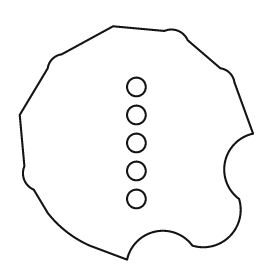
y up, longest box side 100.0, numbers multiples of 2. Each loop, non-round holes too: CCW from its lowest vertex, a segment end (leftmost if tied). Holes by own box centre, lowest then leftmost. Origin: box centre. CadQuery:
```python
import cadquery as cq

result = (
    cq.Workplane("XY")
    .moveTo(-4.0, -50.0)
    .threePointArc((8.0, -38.0), (24.0, -44.0))
    .threePointArc((40.0, -40.0), (44.0, -24.0))
    .threePointArc((38.0, -8.0), (50.0, 4.0))
    .lineTo(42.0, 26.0)
    .threePointArc((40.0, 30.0), (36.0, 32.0))
    .lineTo(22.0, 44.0)
    .threePointArc((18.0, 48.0), (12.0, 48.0))
    .lineTo(-10.0, 50.0)
    .lineTo(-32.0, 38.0)
    .threePointArc((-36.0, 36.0), (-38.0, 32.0))
    .lineTo(-50.0, 12.0)
    .lineTo(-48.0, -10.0)
    .threePointArc((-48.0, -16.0), (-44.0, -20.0))
    .lineTo(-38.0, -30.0)
    .threePointArc((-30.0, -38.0), (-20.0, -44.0))
    .close()
    .moveTo(0.0, -24.0)
    .circle(4.0)
    .moveTo(0.0, -12.0)
    .circle(4.0)
    .moveTo(0.0, 0.0)
    .circle(4.0)
    .moveTo(0.0, 12.0)
    .circle(4.0)
    .moveTo(0.0, 24.0)
    .circle(4.0)
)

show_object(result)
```